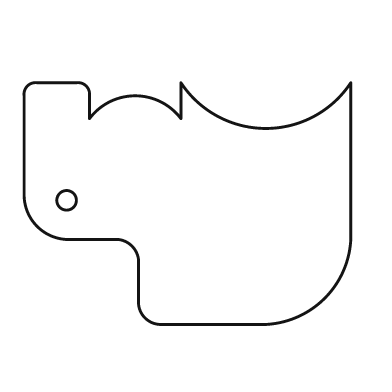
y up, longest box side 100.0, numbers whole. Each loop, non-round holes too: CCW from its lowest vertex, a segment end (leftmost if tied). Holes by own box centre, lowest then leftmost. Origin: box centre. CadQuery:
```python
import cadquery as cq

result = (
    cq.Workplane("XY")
    .moveTo(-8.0, -37.0)
    .lineTo(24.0, -37.0)
    .threePointArc((42.0, -29.0), (50.0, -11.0))
    .lineTo(50.0, 37.0)
    .threePointArc((24.0, 23.0), (-2.0, 37.0))
    .lineTo(-2.0, 26.0)
    .threePointArc((-16.0, 33.0), (-30.0, 26.0))
    .lineTo(-30.0, 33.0)
    .threePointArc((-31.0, 36.0), (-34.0, 37.0))
    .lineTo(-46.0, 37.0)
    .threePointArc((-49.0, 36.0), (-50.0, 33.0))
    .lineTo(-50.0, 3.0)
    .threePointArc((-46.0, -7.0), (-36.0, -11.0))
    .lineTo(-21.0, -11.0)
    .threePointArc((-17.0, -13.0), (-15.0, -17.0))
    .lineTo(-15.0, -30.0)
    .threePointArc((-13.0, -35.0), (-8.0, -37.0))
    .close()
    .moveTo(-37.0, 1.0)
    .circle(3.0)
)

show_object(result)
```